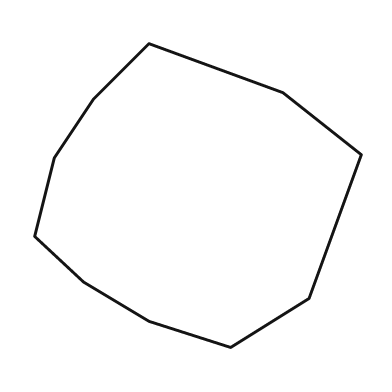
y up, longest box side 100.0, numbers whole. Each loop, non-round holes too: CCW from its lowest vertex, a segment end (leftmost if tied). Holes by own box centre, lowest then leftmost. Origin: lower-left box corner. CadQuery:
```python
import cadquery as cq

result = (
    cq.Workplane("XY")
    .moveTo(60.0, 0.0)
    .lineTo(84.0, 15.0)
    .lineTo(100.0, 59.0)
    .lineTo(76.0, 78.0)
    .lineTo(35.0, 93.0)
    .lineTo(18.0, 76.0)
    .lineTo(6.0, 58.0)
    .lineTo(0.0, 34.0)
    .lineTo(15.0, 20.0)
    .lineTo(35.0, 8.0)
    .close()
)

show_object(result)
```